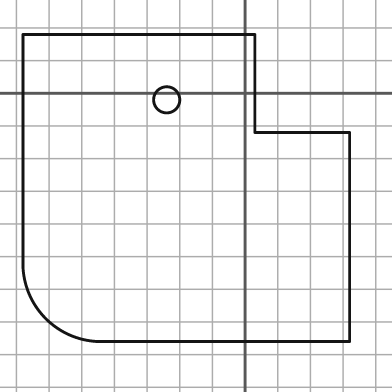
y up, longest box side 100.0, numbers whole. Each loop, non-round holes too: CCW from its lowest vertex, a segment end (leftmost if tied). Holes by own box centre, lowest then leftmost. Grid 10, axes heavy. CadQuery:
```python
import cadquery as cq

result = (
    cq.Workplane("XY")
    .moveTo(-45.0, -76.0)
    .lineTo(32.0, -76.0)
    .lineTo(32.0, -12.0)
    .lineTo(3.0, -12.0)
    .lineTo(3.0, 18.0)
    .lineTo(-68.0, 18.0)
    .lineTo(-68.0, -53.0)
    .threePointArc((-61.0, -69.0), (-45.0, -76.0))
    .close()
    .moveTo(-24.0, -2.0)
    .circle(4.0)
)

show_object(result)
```